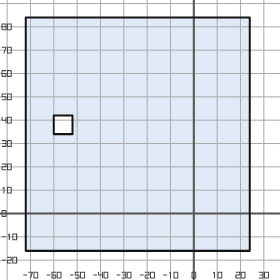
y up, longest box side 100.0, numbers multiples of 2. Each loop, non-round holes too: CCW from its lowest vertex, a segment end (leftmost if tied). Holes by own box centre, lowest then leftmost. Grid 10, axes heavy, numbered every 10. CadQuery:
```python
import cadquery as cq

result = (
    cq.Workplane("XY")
    .moveTo(-72.0, -16.0)
    .lineTo(24.0, -16.0)
    .lineTo(24.0, 84.0)
    .lineTo(-72.0, 84.0)
    .close()
    .moveTo(-60.0, 34.0)
    .lineTo(-52.0, 34.0)
    .lineTo(-52.0, 42.0)
    .lineTo(-60.0, 42.0)
    .close()
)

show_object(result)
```